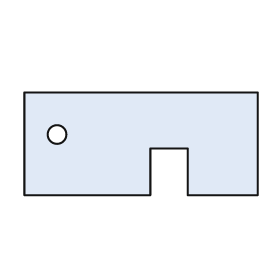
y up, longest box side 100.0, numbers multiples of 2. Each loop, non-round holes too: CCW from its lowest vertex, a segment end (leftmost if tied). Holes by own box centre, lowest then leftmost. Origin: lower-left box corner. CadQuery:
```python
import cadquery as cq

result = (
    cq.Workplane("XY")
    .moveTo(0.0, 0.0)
    .lineTo(54.0, 0.0)
    .lineTo(54.0, 20.0)
    .lineTo(70.0, 20.0)
    .lineTo(70.0, 0.0)
    .lineTo(100.0, 0.0)
    .lineTo(100.0, 44.0)
    .lineTo(0.0, 44.0)
    .close()
    .moveTo(14.0, 26.0)
    .circle(4.0)
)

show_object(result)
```